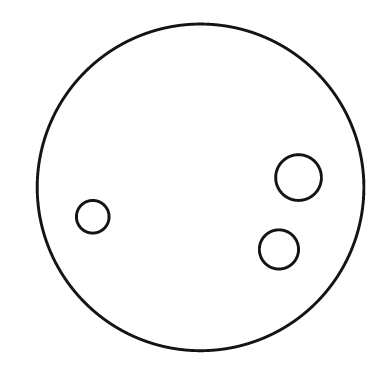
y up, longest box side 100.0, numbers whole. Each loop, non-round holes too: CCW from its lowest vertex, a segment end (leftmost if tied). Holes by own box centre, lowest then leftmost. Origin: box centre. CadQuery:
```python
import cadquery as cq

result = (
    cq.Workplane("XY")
    .moveTo(0.0, 0.0)
    .circle(50.0)
    .moveTo(24.0, -19.0)
    .circle(6.0)
    .moveTo(-33.0, -9.0)
    .circle(5.0)
    .moveTo(30.0, 3.0)
    .circle(7.0)
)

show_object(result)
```